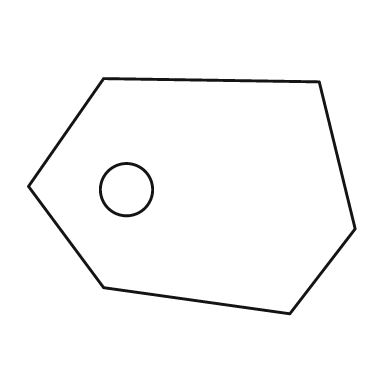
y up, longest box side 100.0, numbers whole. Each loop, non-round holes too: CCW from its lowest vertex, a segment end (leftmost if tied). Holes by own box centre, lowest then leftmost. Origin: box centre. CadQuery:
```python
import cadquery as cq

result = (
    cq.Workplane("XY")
    .moveTo(30.0, -36.0)
    .lineTo(50.0, -10.0)
    .lineTo(39.0, 35.0)
    .lineTo(-27.0, 36.0)
    .lineTo(-50.0, 3.0)
    .lineTo(-27.0, -28.0)
    .close()
    .moveTo(-20.0, 2.0)
    .circle(8.0)
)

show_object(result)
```